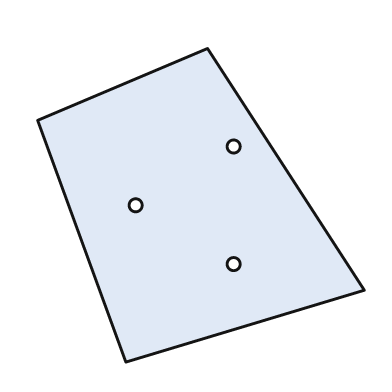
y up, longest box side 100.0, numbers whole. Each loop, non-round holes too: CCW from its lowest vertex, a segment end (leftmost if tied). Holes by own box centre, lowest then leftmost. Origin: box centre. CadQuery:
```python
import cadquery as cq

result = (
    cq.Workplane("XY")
    .moveTo(-23.0, -48.0)
    .lineTo(50.0, -26.0)
    .lineTo(2.0, 48.0)
    .lineTo(-50.0, 26.0)
    .close()
    .moveTo(10.0, -18.0)
    .circle(2.0)
    .moveTo(-20.0, 0.0)
    .circle(2.0)
    .moveTo(10.0, 18.0)
    .circle(2.0)
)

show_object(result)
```